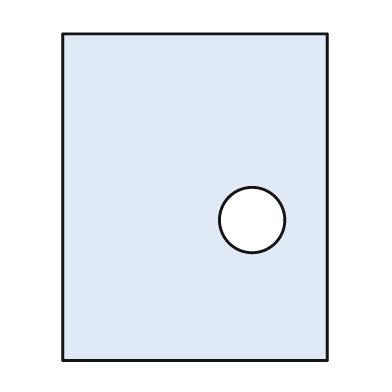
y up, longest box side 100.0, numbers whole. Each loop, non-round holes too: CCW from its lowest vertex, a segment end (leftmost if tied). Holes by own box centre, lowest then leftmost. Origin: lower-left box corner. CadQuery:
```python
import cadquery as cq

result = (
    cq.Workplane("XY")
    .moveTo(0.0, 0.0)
    .lineTo(81.0, 0.0)
    .lineTo(81.0, 100.0)
    .lineTo(0.0, 100.0)
    .close()
    .moveTo(58.0, 43.0)
    .circle(10.0)
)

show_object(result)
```